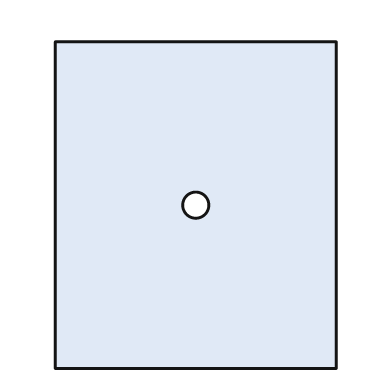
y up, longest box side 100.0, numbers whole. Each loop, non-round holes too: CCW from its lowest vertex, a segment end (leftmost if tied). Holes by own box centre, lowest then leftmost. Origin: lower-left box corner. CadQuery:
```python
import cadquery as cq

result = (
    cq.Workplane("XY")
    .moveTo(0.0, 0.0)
    .lineTo(86.0, 0.0)
    .lineTo(86.0, 100.0)
    .lineTo(0.0, 100.0)
    .close()
    .moveTo(43.0, 50.0)
    .circle(4.0)
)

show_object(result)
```